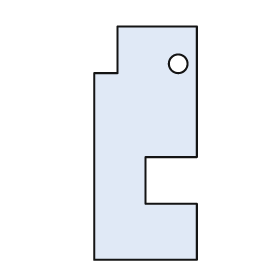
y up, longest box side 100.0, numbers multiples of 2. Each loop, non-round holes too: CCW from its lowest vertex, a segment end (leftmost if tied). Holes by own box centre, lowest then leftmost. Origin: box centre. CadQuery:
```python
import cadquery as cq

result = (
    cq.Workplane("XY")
    .moveTo(-22.0, -50.0)
    .lineTo(22.0, -50.0)
    .lineTo(22.0, -26.0)
    .lineTo(0.0, -26.0)
    .lineTo(0.0, -6.0)
    .lineTo(22.0, -6.0)
    .lineTo(22.0, 50.0)
    .lineTo(-12.0, 50.0)
    .lineTo(-12.0, 30.0)
    .lineTo(-22.0, 30.0)
    .close()
    .moveTo(14.0, 34.0)
    .circle(4.0)
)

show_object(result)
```